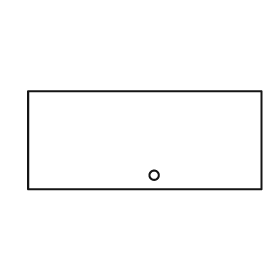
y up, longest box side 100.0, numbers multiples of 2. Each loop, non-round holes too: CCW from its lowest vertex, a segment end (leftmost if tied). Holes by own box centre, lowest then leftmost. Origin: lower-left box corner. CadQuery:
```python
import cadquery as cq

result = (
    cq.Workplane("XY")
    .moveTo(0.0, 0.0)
    .lineTo(100.0, 0.0)
    .lineTo(100.0, 42.0)
    .lineTo(0.0, 42.0)
    .close()
    .moveTo(54.0, 6.0)
    .circle(2.0)
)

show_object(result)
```